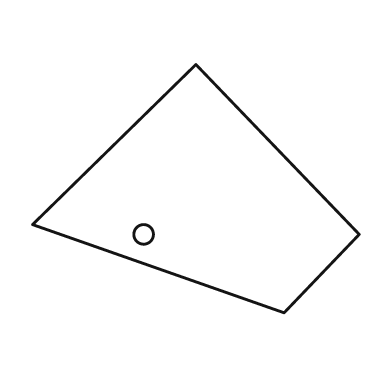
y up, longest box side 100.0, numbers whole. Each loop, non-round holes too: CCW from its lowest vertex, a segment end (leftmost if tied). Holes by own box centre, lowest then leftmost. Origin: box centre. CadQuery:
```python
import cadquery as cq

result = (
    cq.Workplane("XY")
    .moveTo(27.0, -38.0)
    .lineTo(50.0, -14.0)
    .lineTo(0.0, 38.0)
    .lineTo(-50.0, -11.0)
    .close()
    .moveTo(-16.0, -14.0)
    .circle(3.0)
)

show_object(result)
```